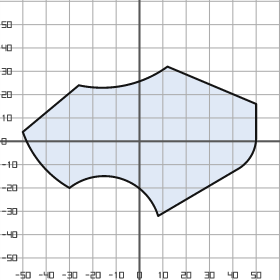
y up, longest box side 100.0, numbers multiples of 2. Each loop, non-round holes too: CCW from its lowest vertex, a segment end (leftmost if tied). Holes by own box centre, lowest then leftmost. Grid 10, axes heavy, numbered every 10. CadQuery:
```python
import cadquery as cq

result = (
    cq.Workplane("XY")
    .moveTo(8.0, -32.0)
    .lineTo(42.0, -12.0)
    .threePointArc((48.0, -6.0), (50.0, 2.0))
    .lineTo(50.0, 16.0)
    .lineTo(12.0, 32.0)
    .threePointArc((-6.0, 24.0), (-26.0, 24.0))
    .lineTo(-50.0, 4.0)
    .threePointArc((-42.0, -10.0), (-30.0, -20.0))
    .threePointArc((-8.0, -16.0), (8.0, -32.0))
    .close()
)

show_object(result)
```